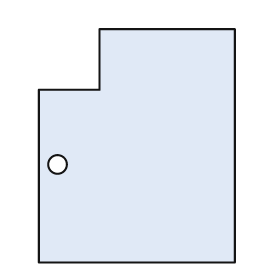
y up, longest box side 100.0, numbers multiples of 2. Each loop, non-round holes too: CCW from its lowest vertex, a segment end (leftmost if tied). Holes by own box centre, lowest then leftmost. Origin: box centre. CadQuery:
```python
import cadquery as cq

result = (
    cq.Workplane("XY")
    .moveTo(-42.0, -50.0)
    .lineTo(42.0, -50.0)
    .lineTo(42.0, 50.0)
    .lineTo(-16.0, 50.0)
    .lineTo(-16.0, 24.0)
    .lineTo(-42.0, 24.0)
    .close()
    .moveTo(-34.0, -8.0)
    .circle(4.0)
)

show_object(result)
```